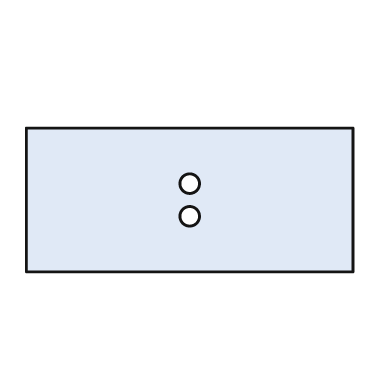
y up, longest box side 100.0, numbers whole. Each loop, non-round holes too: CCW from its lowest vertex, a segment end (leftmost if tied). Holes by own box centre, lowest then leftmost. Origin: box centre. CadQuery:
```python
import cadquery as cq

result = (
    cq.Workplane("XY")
    .moveTo(-50.0, -22.0)
    .lineTo(50.0, -22.0)
    .lineTo(50.0, 22.0)
    .lineTo(-50.0, 22.0)
    .close()
    .moveTo(0.0, -5.0)
    .circle(3.0)
    .moveTo(0.0, 5.0)
    .circle(3.0)
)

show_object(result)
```